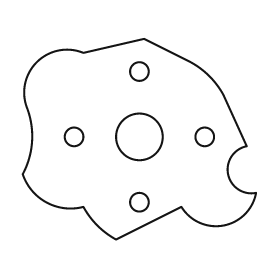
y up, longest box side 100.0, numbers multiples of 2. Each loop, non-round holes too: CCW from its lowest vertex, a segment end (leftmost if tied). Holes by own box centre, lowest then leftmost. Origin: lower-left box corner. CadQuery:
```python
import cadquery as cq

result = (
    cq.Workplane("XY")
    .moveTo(40.0, 0.0)
    .lineTo(68.0, 14.0)
    .threePointArc((86.0, 6.0), (100.0, 20.0))
    .threePointArc((88.0, 28.0), (96.0, 40.0))
    .lineTo(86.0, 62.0)
    .threePointArc((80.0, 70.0), (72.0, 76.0))
    .lineTo(52.0, 86.0)
    .lineTo(26.0, 80.0)
    .threePointArc((6.0, 76.0), (2.0, 56.0))
    .threePointArc((4.0, 42.0), (0.0, 28.0))
    .threePointArc((10.0, 16.0), (26.0, 14.0))
    .threePointArc((32.0, 6.0), (40.0, 0.0))
    .close()
    .moveTo(50.0, 16.0)
    .circle(4.0)
    .moveTo(22.0, 44.0)
    .circle(4.0)
    .moveTo(50.0, 44.0)
    .circle(10.0)
    .moveTo(78.0, 44.0)
    .circle(4.0)
    .moveTo(50.0, 72.0)
    .circle(4.0)
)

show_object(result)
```